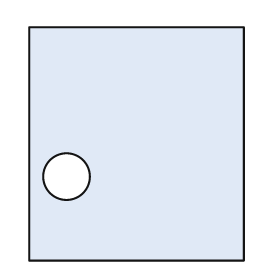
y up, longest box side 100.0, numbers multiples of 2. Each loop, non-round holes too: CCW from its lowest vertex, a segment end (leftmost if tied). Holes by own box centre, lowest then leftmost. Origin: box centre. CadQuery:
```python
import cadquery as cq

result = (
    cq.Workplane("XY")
    .moveTo(-46.0, -50.0)
    .lineTo(46.0, -50.0)
    .lineTo(46.0, 50.0)
    .lineTo(-46.0, 50.0)
    .close()
    .moveTo(-30.0, -14.0)
    .circle(10.0)
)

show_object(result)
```